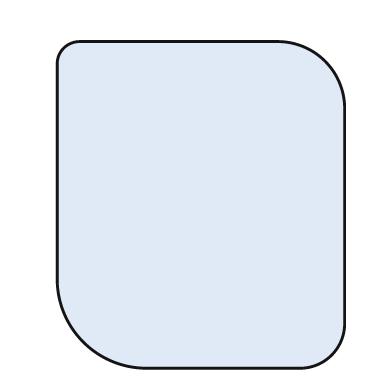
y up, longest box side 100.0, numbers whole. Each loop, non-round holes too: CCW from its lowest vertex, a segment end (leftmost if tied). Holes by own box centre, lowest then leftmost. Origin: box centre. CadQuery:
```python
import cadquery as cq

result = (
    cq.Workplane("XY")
    .moveTo(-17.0, -50.0)
    .lineTo(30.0, -50.0)
    .threePointArc((40.0, -46.0), (44.0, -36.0))
    .lineTo(44.0, 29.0)
    .threePointArc((38.0, 44.0), (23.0, 50.0))
    .lineTo(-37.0, 50.0)
    .threePointArc((-42.0, 48.0), (-44.0, 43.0))
    .lineTo(-44.0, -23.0)
    .threePointArc((-36.0, -42.0), (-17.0, -50.0))
    .close()
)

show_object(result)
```